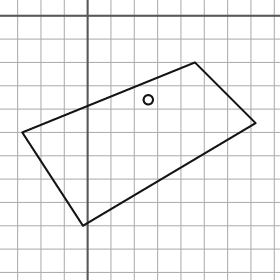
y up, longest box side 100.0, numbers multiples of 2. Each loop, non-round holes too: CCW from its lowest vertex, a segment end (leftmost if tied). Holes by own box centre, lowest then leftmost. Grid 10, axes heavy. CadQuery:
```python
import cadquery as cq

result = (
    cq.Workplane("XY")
    .moveTo(-2.0, -90.0)
    .lineTo(72.0, -46.0)
    .lineTo(46.0, -20.0)
    .lineTo(-28.0, -50.0)
    .close()
    .moveTo(26.0, -36.0)
    .circle(2.0)
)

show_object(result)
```